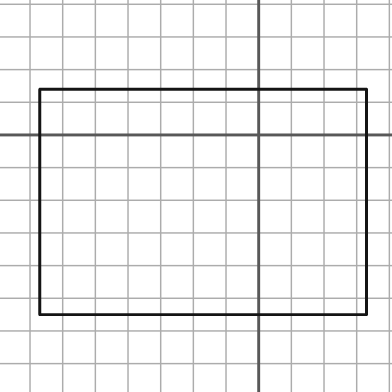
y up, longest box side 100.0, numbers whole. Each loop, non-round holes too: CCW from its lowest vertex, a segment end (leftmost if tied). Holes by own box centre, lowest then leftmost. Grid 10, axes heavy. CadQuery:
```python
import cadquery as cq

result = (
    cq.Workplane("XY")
    .moveTo(-67.0, -55.0)
    .lineTo(33.0, -55.0)
    .lineTo(33.0, 14.0)
    .lineTo(-67.0, 14.0)
    .close()
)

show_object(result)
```